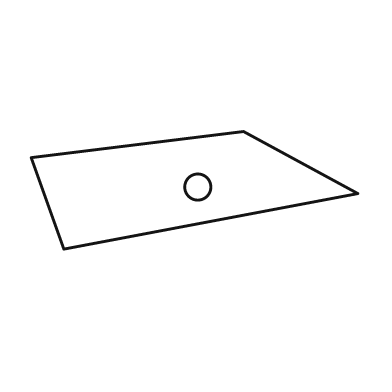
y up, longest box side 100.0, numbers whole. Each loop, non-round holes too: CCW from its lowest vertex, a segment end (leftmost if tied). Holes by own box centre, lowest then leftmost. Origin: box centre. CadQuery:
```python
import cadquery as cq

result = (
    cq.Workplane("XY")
    .moveTo(-40.0, -18.0)
    .lineTo(50.0, -1.0)
    .lineTo(15.0, 18.0)
    .lineTo(-50.0, 10.0)
    .close()
    .moveTo(1.0, 1.0)
    .circle(4.0)
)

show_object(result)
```